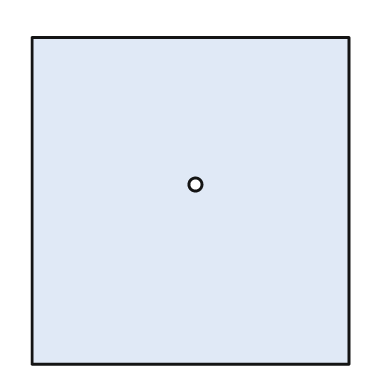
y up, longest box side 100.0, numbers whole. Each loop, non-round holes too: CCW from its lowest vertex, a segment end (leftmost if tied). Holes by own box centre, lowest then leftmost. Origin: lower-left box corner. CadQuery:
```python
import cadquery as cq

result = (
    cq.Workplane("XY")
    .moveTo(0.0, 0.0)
    .lineTo(97.0, 0.0)
    .lineTo(97.0, 100.0)
    .lineTo(0.0, 100.0)
    .close()
    .moveTo(50.0, 55.0)
    .circle(2.0)
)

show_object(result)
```